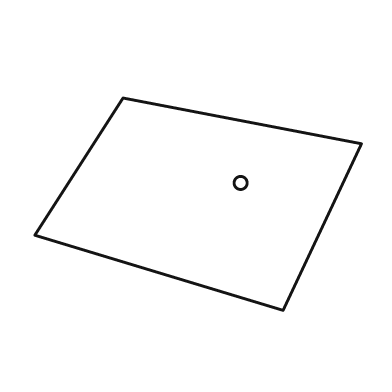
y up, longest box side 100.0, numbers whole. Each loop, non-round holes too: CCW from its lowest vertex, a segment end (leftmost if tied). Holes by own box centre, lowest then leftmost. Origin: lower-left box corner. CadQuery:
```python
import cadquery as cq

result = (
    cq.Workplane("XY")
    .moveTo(76.0, 0.0)
    .lineTo(100.0, 51.0)
    .lineTo(27.0, 65.0)
    .lineTo(0.0, 23.0)
    .close()
    .moveTo(63.0, 39.0)
    .circle(2.0)
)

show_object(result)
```